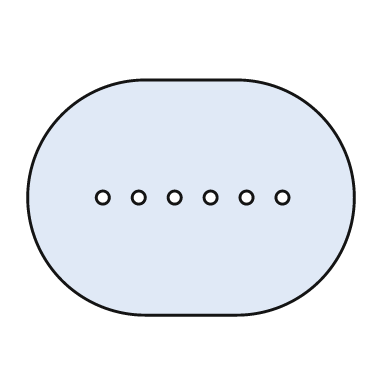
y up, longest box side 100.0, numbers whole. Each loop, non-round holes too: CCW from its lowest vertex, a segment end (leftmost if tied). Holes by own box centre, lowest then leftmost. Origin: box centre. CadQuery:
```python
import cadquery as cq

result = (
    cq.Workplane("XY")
    .moveTo(-14.0, -36.0)
    .lineTo(14.0, -36.0)
    .threePointArc((50.0, 0.0), (14.0, 36.0))
    .lineTo(-14.0, 36.0)
    .threePointArc((-50.0, 0.0), (-14.0, -36.0))
    .close()
    .moveTo(-27.0, 0.0)
    .circle(2.0)
    .moveTo(-16.0, 0.0)
    .circle(2.0)
    .moveTo(-5.0, 0.0)
    .circle(2.0)
    .moveTo(6.0, 0.0)
    .circle(2.0)
    .moveTo(17.0, 0.0)
    .circle(2.0)
    .moveTo(28.0, 0.0)
    .circle(2.0)
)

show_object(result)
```